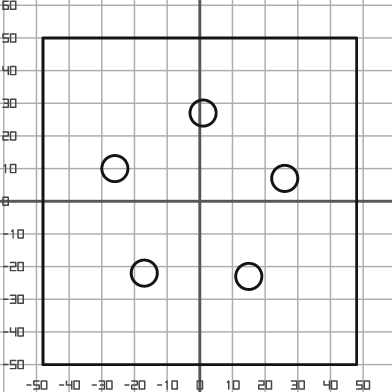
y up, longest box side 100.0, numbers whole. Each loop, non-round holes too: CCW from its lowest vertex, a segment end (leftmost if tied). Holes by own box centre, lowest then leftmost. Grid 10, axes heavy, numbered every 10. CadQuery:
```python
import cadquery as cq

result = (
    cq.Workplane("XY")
    .moveTo(-48.0, -50.0)
    .lineTo(48.0, -50.0)
    .lineTo(48.0, 50.0)
    .lineTo(-48.0, 50.0)
    .close()
    .moveTo(15.0, -23.0)
    .circle(4.0)
    .moveTo(-17.0, -22.0)
    .circle(4.0)
    .moveTo(26.0, 7.0)
    .circle(4.0)
    .moveTo(-26.0, 10.0)
    .circle(4.0)
    .moveTo(1.0, 27.0)
    .circle(4.0)
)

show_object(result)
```